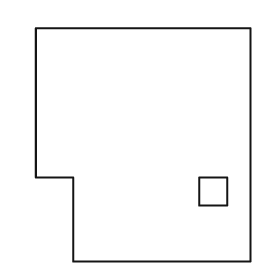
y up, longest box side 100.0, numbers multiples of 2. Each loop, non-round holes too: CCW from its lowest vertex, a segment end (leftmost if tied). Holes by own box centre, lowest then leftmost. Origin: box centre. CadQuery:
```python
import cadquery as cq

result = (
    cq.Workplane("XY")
    .moveTo(-30.0, -50.0)
    .lineTo(46.0, -50.0)
    .lineTo(46.0, 50.0)
    .lineTo(-46.0, 50.0)
    .lineTo(-46.0, -14.0)
    .lineTo(-30.0, -14.0)
    .close()
    .moveTo(24.0, -26.0)
    .lineTo(36.0, -26.0)
    .lineTo(36.0, -14.0)
    .lineTo(24.0, -14.0)
    .close()
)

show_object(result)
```